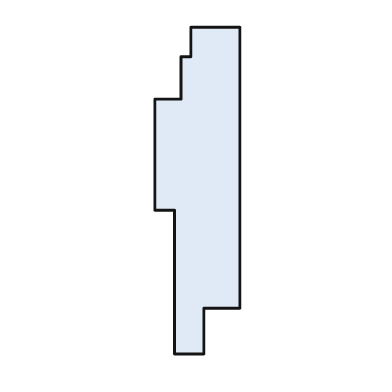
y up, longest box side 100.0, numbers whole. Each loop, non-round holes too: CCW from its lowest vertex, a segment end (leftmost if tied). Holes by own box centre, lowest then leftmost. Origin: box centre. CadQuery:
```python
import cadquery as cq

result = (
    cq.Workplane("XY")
    .moveTo(-7.0, -50.0)
    .lineTo(2.0, -50.0)
    .lineTo(2.0, -36.0)
    .lineTo(13.0, -36.0)
    .lineTo(13.0, 50.0)
    .lineTo(-2.0, 50.0)
    .lineTo(-2.0, 41.0)
    .lineTo(-5.0, 41.0)
    .lineTo(-5.0, 28.0)
    .lineTo(-13.0, 28.0)
    .lineTo(-13.0, -6.0)
    .lineTo(-7.0, -6.0)
    .close()
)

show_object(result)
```